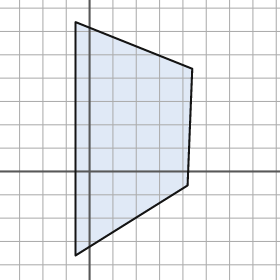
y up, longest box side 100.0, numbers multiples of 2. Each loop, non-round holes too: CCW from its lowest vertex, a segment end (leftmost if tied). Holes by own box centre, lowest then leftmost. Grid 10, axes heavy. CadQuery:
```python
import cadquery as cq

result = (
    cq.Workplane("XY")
    .moveTo(-6.0, -36.0)
    .lineTo(42.0, -6.0)
    .lineTo(44.0, 44.0)
    .lineTo(-6.0, 64.0)
    .close()
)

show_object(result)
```